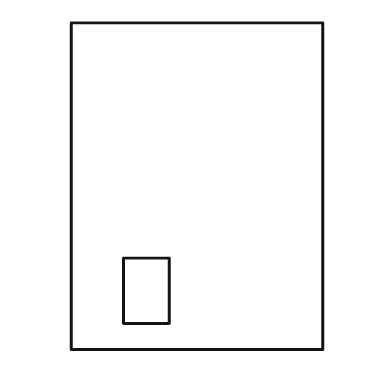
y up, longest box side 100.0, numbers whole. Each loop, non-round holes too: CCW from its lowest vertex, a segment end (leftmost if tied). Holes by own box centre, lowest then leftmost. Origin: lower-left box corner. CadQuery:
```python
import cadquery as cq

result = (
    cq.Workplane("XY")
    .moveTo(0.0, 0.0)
    .lineTo(77.0, 0.0)
    .lineTo(77.0, 100.0)
    .lineTo(0.0, 100.0)
    .close()
    .moveTo(16.0, 8.0)
    .lineTo(30.0, 8.0)
    .lineTo(30.0, 28.0)
    .lineTo(16.0, 28.0)
    .close()
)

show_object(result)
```